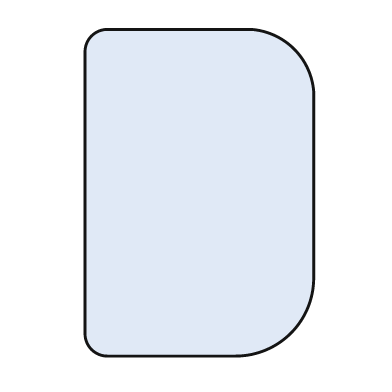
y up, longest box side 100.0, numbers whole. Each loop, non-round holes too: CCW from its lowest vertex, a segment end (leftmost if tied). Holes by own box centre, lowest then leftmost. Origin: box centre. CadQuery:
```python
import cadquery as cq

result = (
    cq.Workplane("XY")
    .moveTo(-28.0, -50.0)
    .lineTo(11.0, -50.0)
    .threePointArc((28.0, -43.0), (35.0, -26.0))
    .lineTo(35.0, 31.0)
    .threePointArc((29.0, 44.0), (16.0, 50.0))
    .lineTo(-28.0, 50.0)
    .threePointArc((-33.0, 48.0), (-35.0, 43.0))
    .lineTo(-35.0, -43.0)
    .threePointArc((-33.0, -48.0), (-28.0, -50.0))
    .close()
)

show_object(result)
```